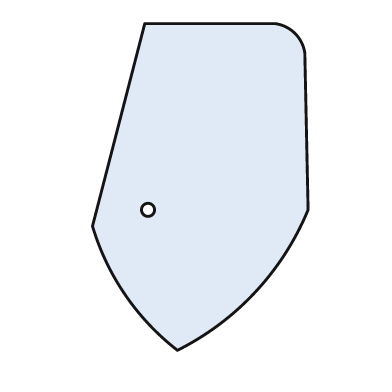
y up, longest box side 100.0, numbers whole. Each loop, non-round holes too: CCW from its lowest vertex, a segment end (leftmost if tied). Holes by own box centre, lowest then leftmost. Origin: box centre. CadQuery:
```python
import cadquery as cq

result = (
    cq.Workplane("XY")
    .moveTo(-7.0, -50.0)
    .threePointArc((17.0, -32.0), (33.0, -7.0))
    .lineTo(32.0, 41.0)
    .threePointArc((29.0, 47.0), (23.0, 50.0))
    .lineTo(-17.0, 50.0)
    .lineTo(-33.0, -12.0)
    .threePointArc((-23.0, -33.0), (-7.0, -50.0))
    .close()
    .moveTo(-16.0, -7.0)
    .circle(2.0)
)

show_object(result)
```